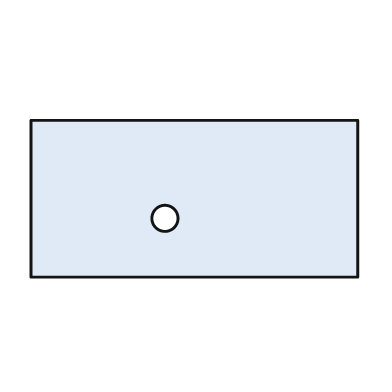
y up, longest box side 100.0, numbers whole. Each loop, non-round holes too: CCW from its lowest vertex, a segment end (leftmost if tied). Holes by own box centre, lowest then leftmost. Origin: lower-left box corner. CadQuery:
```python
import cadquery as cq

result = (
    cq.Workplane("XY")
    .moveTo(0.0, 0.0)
    .lineTo(100.0, 0.0)
    .lineTo(100.0, 48.0)
    .lineTo(0.0, 48.0)
    .close()
    .moveTo(41.0, 18.0)
    .circle(4.0)
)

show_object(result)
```